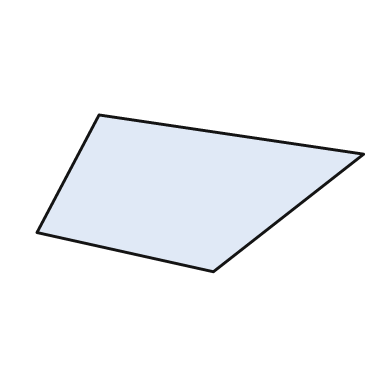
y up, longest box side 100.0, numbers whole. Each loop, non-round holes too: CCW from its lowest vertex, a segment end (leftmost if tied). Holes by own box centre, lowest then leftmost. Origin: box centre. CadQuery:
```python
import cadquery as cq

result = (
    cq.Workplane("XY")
    .moveTo(4.0, -24.0)
    .lineTo(50.0, 12.0)
    .lineTo(-31.0, 24.0)
    .lineTo(-50.0, -12.0)
    .close()
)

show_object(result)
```